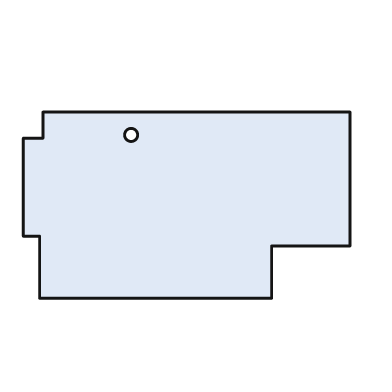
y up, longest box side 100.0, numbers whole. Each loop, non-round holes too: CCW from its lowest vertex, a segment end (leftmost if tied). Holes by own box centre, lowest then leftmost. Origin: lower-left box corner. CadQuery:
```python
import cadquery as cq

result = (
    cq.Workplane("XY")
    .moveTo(5.0, 0.0)
    .lineTo(76.0, 0.0)
    .lineTo(76.0, 16.0)
    .lineTo(100.0, 16.0)
    .lineTo(100.0, 57.0)
    .lineTo(6.0, 57.0)
    .lineTo(6.0, 49.0)
    .lineTo(0.0, 49.0)
    .lineTo(0.0, 19.0)
    .lineTo(5.0, 19.0)
    .close()
    .moveTo(33.0, 50.0)
    .circle(2.0)
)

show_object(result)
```